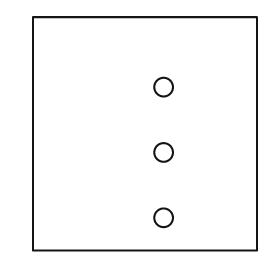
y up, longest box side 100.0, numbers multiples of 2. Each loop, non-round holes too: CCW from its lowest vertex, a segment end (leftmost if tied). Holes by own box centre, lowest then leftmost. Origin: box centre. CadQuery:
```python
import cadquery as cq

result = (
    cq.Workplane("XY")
    .moveTo(-48.0, -50.0)
    .lineTo(48.0, -50.0)
    .lineTo(48.0, 50.0)
    .lineTo(-48.0, 50.0)
    .close()
    .moveTo(8.0, -36.0)
    .circle(4.0)
    .moveTo(8.0, -8.0)
    .circle(4.0)
    .moveTo(8.0, 20.0)
    .circle(4.0)
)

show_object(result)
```